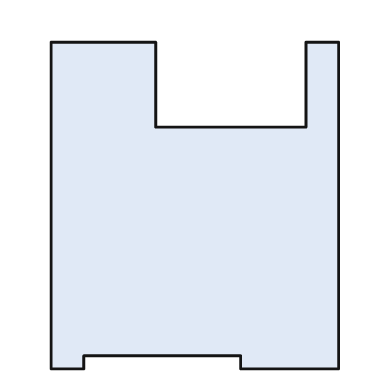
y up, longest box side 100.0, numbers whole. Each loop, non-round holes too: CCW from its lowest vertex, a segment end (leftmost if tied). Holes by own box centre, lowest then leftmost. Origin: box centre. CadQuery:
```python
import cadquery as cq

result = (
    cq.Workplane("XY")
    .moveTo(-44.0, -50.0)
    .lineTo(-34.0, -50.0)
    .lineTo(-34.0, -46.0)
    .lineTo(14.0, -46.0)
    .lineTo(14.0, -50.0)
    .lineTo(44.0, -50.0)
    .lineTo(44.0, 50.0)
    .lineTo(34.0, 50.0)
    .lineTo(34.0, 24.0)
    .lineTo(-12.0, 24.0)
    .lineTo(-12.0, 50.0)
    .lineTo(-44.0, 50.0)
    .close()
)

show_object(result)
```